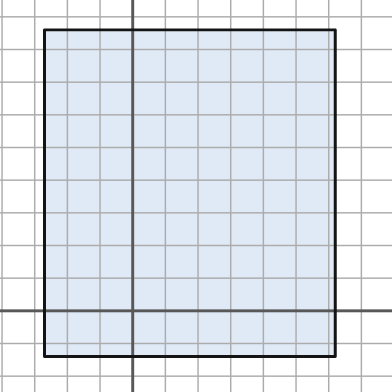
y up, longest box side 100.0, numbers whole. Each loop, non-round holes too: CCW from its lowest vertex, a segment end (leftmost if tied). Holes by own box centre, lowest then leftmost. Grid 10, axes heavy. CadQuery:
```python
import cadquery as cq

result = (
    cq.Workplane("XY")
    .moveTo(-27.0, -14.0)
    .lineTo(62.0, -14.0)
    .lineTo(62.0, 86.0)
    .lineTo(-27.0, 86.0)
    .close()
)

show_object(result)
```